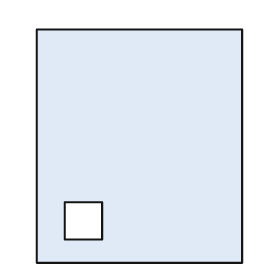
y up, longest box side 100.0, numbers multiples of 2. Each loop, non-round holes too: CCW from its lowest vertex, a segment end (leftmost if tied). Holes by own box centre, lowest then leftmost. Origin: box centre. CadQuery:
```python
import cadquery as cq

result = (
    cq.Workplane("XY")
    .moveTo(-44.0, -50.0)
    .lineTo(44.0, -50.0)
    .lineTo(44.0, 50.0)
    .lineTo(-44.0, 50.0)
    .close()
    .moveTo(-32.0, -40.0)
    .lineTo(-16.0, -40.0)
    .lineTo(-16.0, -24.0)
    .lineTo(-32.0, -24.0)
    .close()
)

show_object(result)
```